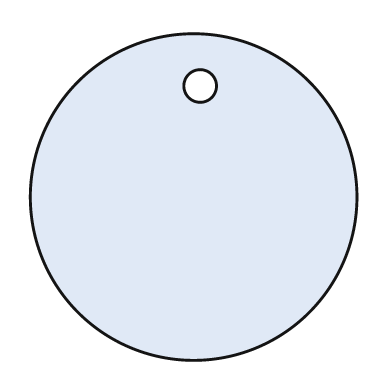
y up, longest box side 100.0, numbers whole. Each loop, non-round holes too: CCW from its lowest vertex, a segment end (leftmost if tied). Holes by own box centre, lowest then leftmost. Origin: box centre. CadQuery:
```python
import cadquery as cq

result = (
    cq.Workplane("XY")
    .moveTo(0.0, 0.0)
    .circle(50.0)
    .moveTo(2.0, 34.0)
    .circle(5.0)
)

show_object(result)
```